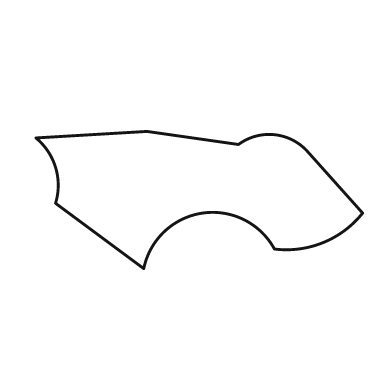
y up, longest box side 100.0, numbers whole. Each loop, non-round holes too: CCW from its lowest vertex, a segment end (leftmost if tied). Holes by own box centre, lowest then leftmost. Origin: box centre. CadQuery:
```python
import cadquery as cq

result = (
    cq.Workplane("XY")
    .moveTo(-17.0, -21.0)
    .threePointArc((1.0, -4.0), (23.0, -15.0))
    .threePointArc((38.0, -13.0), (50.0, -4.0))
    .lineTo(33.0, 15.0)
    .threePointArc((23.0, 20.0), (12.0, 17.0))
    .lineTo(-16.0, 21.0)
    .lineTo(-50.0, 19.0)
    .threePointArc((-44.0, 10.0), (-44.0, -1.0))
    .close()
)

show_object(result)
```